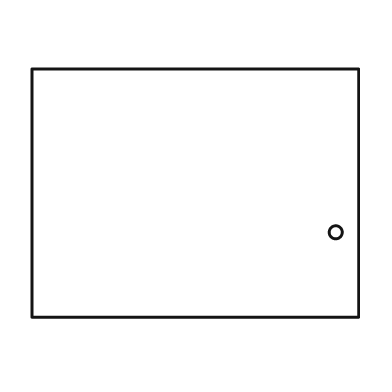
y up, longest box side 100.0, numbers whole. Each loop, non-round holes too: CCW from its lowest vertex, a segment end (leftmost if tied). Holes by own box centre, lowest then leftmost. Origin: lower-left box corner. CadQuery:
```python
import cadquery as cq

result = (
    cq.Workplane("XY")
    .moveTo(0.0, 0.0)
    .lineTo(100.0, 0.0)
    .lineTo(100.0, 76.0)
    .lineTo(0.0, 76.0)
    .close()
    .moveTo(93.0, 26.0)
    .circle(2.0)
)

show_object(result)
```